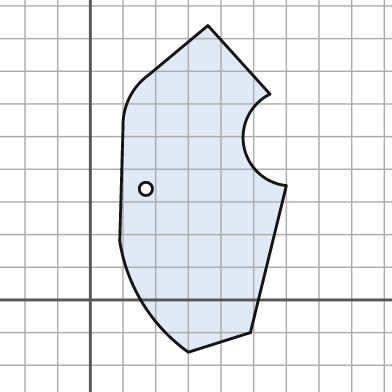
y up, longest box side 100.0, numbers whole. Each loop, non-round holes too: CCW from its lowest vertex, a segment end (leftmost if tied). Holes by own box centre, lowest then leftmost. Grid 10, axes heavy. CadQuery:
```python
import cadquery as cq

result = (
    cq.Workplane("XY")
    .moveTo(30.0, -16.0)
    .lineTo(49.0, -10.0)
    .lineTo(60.0, 35.0)
    .threePointArc((47.0, 47.0), (55.0, 63.0))
    .lineTo(36.0, 84.0)
    .lineTo(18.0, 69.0)
    .threePointArc((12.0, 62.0), (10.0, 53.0))
    .lineTo(9.0, 18.0)
    .threePointArc((16.0, -1.0), (30.0, -16.0))
    .close()
    .moveTo(17.0, 34.0)
    .circle(2.0)
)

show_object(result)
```